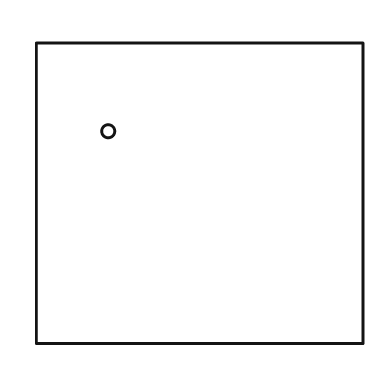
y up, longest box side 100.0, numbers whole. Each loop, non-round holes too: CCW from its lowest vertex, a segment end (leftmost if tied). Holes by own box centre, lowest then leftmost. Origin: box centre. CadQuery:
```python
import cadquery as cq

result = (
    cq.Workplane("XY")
    .moveTo(-50.0, -46.0)
    .lineTo(50.0, -46.0)
    .lineTo(50.0, 46.0)
    .lineTo(-50.0, 46.0)
    .close()
    .moveTo(-28.0, 19.0)
    .circle(2.0)
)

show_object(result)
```